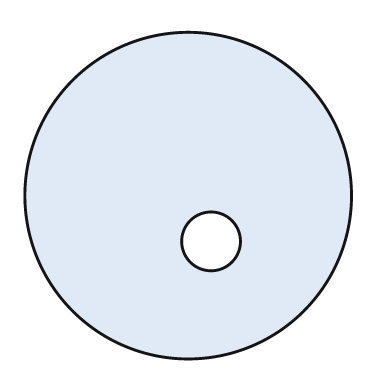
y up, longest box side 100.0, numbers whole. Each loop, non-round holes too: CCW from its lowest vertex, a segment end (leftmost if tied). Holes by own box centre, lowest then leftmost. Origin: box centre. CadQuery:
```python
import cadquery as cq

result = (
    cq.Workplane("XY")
    .moveTo(0.0, 0.0)
    .circle(50.0)
    .moveTo(7.0, -14.0)
    .circle(9.0)
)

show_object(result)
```